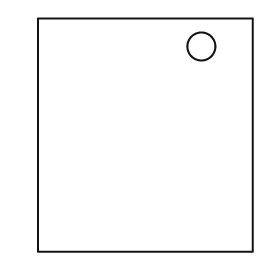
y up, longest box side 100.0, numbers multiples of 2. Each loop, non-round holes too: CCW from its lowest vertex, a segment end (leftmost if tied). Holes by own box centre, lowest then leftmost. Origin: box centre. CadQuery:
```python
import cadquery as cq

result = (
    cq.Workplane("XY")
    .moveTo(-46.0, -50.0)
    .lineTo(46.0, -50.0)
    .lineTo(46.0, 50.0)
    .lineTo(-46.0, 50.0)
    .close()
    .moveTo(24.0, 38.0)
    .circle(6.0)
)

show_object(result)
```